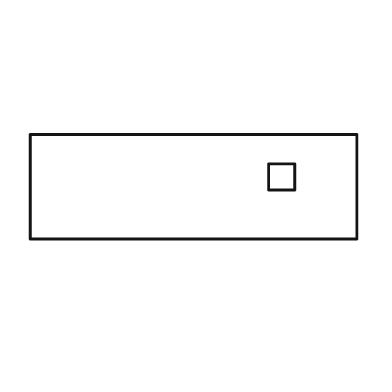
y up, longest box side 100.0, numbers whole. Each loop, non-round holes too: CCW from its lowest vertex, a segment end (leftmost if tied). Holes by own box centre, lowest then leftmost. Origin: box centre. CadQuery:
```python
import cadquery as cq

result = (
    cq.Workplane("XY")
    .moveTo(-50.0, -16.0)
    .lineTo(50.0, -16.0)
    .lineTo(50.0, 16.0)
    .lineTo(-50.0, 16.0)
    .close()
    .moveTo(23.0, -1.0)
    .lineTo(31.0, -1.0)
    .lineTo(31.0, 7.0)
    .lineTo(23.0, 7.0)
    .close()
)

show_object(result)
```